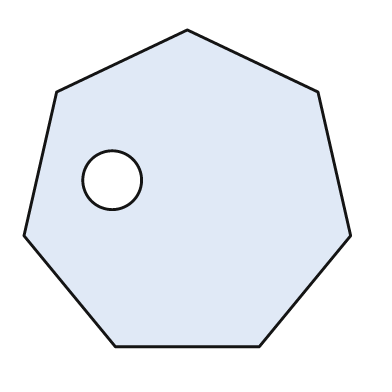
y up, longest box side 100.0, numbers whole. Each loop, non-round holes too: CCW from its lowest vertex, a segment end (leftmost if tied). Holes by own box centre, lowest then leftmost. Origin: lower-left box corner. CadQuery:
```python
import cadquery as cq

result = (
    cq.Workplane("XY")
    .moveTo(28.0, 0.0)
    .lineTo(72.0, 0.0)
    .lineTo(100.0, 34.0)
    .lineTo(90.0, 78.0)
    .lineTo(50.0, 97.0)
    .lineTo(10.0, 78.0)
    .lineTo(0.0, 34.0)
    .close()
    .moveTo(27.0, 51.0)
    .circle(9.0)
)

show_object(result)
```